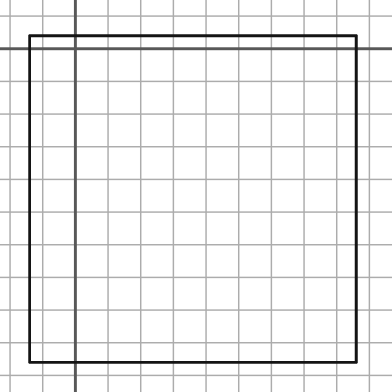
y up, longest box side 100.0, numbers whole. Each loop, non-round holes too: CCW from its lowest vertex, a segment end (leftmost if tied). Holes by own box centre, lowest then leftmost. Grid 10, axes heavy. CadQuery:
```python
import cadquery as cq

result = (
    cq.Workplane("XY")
    .moveTo(-14.0, -96.0)
    .lineTo(86.0, -96.0)
    .lineTo(86.0, 4.0)
    .lineTo(-14.0, 4.0)
    .close()
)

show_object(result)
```